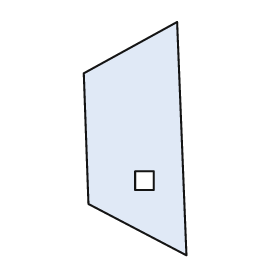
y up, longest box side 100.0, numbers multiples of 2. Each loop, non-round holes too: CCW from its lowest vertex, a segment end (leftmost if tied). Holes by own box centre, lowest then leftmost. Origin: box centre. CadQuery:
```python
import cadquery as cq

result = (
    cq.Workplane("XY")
    .moveTo(22.0, -50.0)
    .lineTo(18.0, 50.0)
    .lineTo(-22.0, 28.0)
    .lineTo(-20.0, -28.0)
    .close()
    .moveTo(0.0, -22.0)
    .lineTo(8.0, -22.0)
    .lineTo(8.0, -14.0)
    .lineTo(0.0, -14.0)
    .close()
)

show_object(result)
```